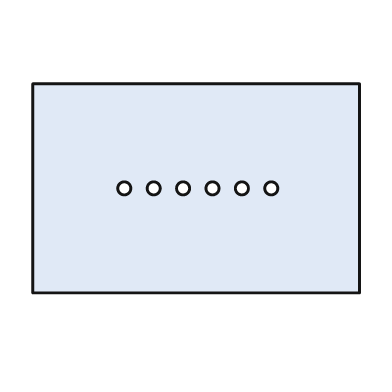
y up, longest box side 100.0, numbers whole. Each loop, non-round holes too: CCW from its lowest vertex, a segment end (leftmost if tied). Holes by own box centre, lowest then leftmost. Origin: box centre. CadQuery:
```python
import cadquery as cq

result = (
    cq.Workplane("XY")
    .moveTo(-50.0, -32.0)
    .lineTo(50.0, -32.0)
    .lineTo(50.0, 32.0)
    .lineTo(-50.0, 32.0)
    .close()
    .moveTo(-22.0, 0.0)
    .circle(2.0)
    .moveTo(-13.0, 0.0)
    .circle(2.0)
    .moveTo(-4.0, 0.0)
    .circle(2.0)
    .moveTo(5.0, 0.0)
    .circle(2.0)
    .moveTo(14.0, 0.0)
    .circle(2.0)
    .moveTo(23.0, 0.0)
    .circle(2.0)
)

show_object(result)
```